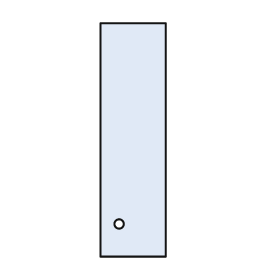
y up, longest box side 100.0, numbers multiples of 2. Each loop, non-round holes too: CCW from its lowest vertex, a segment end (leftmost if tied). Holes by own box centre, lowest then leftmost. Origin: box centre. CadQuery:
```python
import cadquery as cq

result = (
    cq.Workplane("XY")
    .moveTo(-14.0, -50.0)
    .lineTo(14.0, -50.0)
    .lineTo(14.0, 50.0)
    .lineTo(-14.0, 50.0)
    .close()
    .moveTo(-6.0, -36.0)
    .circle(2.0)
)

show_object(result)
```